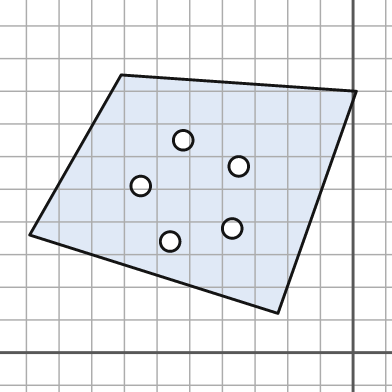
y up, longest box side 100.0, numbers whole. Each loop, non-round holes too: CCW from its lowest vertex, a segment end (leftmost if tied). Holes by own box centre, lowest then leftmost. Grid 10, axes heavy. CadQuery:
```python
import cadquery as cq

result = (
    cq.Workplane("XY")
    .moveTo(-23.0, 12.0)
    .lineTo(1.0, 80.0)
    .lineTo(-71.0, 85.0)
    .lineTo(-99.0, 36.0)
    .close()
    .moveTo(-56.0, 34.0)
    .circle(3.0)
    .moveTo(-37.0, 38.0)
    .circle(3.0)
    .moveTo(-65.0, 51.0)
    .circle(3.0)
    .moveTo(-35.0, 57.0)
    .circle(3.0)
    .moveTo(-52.0, 65.0)
    .circle(3.0)
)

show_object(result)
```